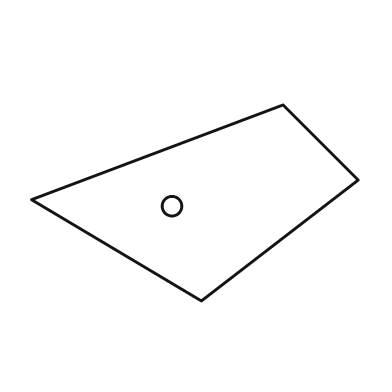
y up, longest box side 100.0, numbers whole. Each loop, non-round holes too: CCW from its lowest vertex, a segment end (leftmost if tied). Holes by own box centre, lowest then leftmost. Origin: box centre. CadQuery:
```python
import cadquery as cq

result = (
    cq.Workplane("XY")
    .moveTo(2.0, -30.0)
    .lineTo(50.0, 7.0)
    .lineTo(27.0, 30.0)
    .lineTo(-50.0, 1.0)
    .close()
    .moveTo(-7.0, -1.0)
    .circle(3.0)
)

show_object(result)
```